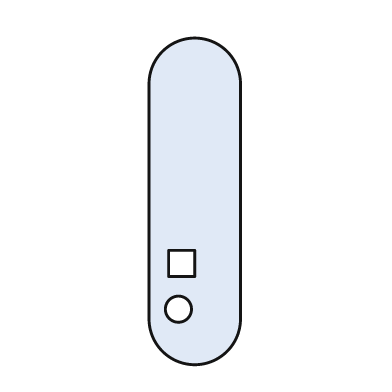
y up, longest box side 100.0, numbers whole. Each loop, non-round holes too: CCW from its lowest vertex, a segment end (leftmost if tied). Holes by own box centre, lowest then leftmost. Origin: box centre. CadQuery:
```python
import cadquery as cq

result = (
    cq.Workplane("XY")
    .moveTo(-14.0, -36.0)
    .threePointArc((0.0, -50.0), (14.0, -36.0))
    .lineTo(14.0, 36.0)
    .threePointArc((0.0, 50.0), (-14.0, 36.0))
    .close()
    .moveTo(-5.0, -33.0)
    .circle(4.0)
    .moveTo(-8.0, -23.0)
    .lineTo(0.0, -23.0)
    .lineTo(0.0, -15.0)
    .lineTo(-8.0, -15.0)
    .close()
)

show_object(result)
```